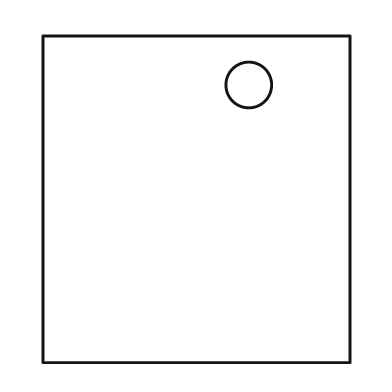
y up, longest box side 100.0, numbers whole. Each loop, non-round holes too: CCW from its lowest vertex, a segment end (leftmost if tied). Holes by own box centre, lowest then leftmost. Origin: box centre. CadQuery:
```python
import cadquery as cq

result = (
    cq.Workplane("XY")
    .moveTo(-47.0, -50.0)
    .lineTo(47.0, -50.0)
    .lineTo(47.0, 50.0)
    .lineTo(-47.0, 50.0)
    .close()
    .moveTo(16.0, 35.0)
    .circle(7.0)
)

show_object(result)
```